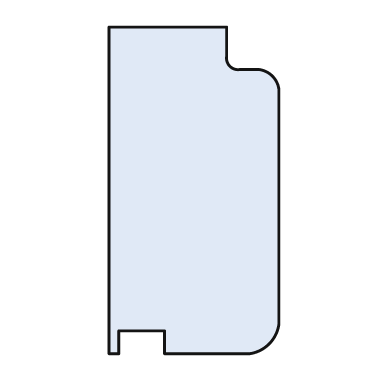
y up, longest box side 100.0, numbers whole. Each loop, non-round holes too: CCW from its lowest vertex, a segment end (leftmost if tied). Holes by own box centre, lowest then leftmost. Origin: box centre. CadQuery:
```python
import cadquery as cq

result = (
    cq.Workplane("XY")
    .moveTo(-26.0, -50.0)
    .lineTo(-23.0, -50.0)
    .lineTo(-23.0, -43.0)
    .lineTo(-9.0, -43.0)
    .lineTo(-9.0, -50.0)
    .lineTo(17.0, -50.0)
    .threePointArc((23.0, -47.0), (26.0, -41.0))
    .lineTo(26.0, 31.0)
    .threePointArc((24.0, 35.0), (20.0, 37.0))
    .lineTo(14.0, 37.0)
    .threePointArc((11.0, 38.0), (10.0, 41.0))
    .lineTo(10.0, 50.0)
    .lineTo(-26.0, 50.0)
    .close()
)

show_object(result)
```